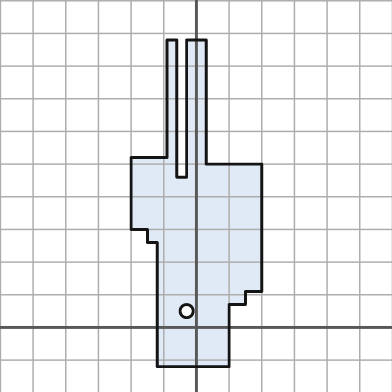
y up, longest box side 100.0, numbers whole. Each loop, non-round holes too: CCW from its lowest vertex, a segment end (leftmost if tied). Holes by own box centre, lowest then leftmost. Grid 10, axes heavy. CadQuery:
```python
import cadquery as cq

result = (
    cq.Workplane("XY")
    .moveTo(-12.0, -12.0)
    .lineTo(10.0, -12.0)
    .lineTo(10.0, 7.0)
    .lineTo(15.0, 7.0)
    .lineTo(15.0, 11.0)
    .lineTo(20.0, 11.0)
    .lineTo(20.0, 50.0)
    .lineTo(3.0, 50.0)
    .lineTo(3.0, 88.0)
    .lineTo(-3.0, 88.0)
    .lineTo(-3.0, 46.0)
    .lineTo(-6.0, 46.0)
    .lineTo(-6.0, 88.0)
    .lineTo(-9.0, 88.0)
    .lineTo(-9.0, 52.0)
    .lineTo(-20.0, 52.0)
    .lineTo(-20.0, 30.0)
    .lineTo(-15.0, 30.0)
    .lineTo(-15.0, 26.0)
    .lineTo(-12.0, 26.0)
    .close()
    .moveTo(-3.0, 5.0)
    .circle(2.0)
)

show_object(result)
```